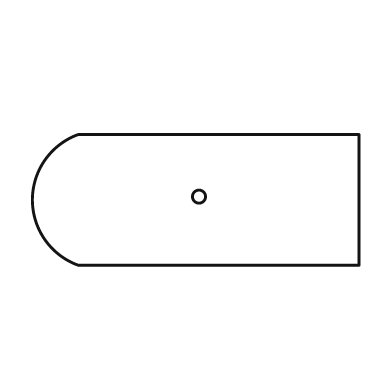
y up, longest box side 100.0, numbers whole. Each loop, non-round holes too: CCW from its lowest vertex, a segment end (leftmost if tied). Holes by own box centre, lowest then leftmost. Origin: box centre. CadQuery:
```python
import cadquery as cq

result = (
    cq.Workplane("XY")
    .moveTo(-36.0, -20.0)
    .lineTo(50.0, -20.0)
    .lineTo(50.0, 20.0)
    .lineTo(-36.0, 20.0)
    .threePointArc((-50.0, 0.0), (-36.0, -20.0))
    .close()
    .moveTo(1.0, 1.0)
    .circle(2.0)
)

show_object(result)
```